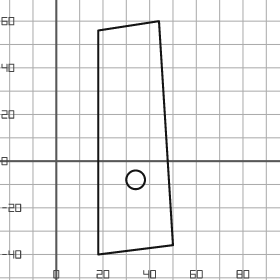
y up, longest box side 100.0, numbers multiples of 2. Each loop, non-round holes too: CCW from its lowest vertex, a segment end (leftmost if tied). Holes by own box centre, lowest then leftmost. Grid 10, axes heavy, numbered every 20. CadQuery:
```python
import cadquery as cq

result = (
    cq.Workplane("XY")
    .moveTo(18.0, -40.0)
    .lineTo(50.0, -36.0)
    .lineTo(44.0, 60.0)
    .lineTo(18.0, 56.0)
    .close()
    .moveTo(34.0, -8.0)
    .circle(4.0)
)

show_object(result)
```